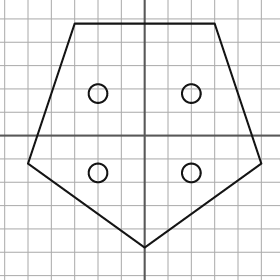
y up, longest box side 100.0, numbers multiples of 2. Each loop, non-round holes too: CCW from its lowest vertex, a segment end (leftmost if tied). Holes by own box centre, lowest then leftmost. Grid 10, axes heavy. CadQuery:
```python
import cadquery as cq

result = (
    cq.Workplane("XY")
    .moveTo(0.0, -48.0)
    .lineTo(50.0, -12.0)
    .lineTo(30.0, 48.0)
    .lineTo(-30.0, 48.0)
    .lineTo(-50.0, -12.0)
    .close()
    .moveTo(-20.0, -16.0)
    .circle(4.0)
    .moveTo(20.0, -16.0)
    .circle(4.0)
    .moveTo(-20.0, 18.0)
    .circle(4.0)
    .moveTo(20.0, 18.0)
    .circle(4.0)
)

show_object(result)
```